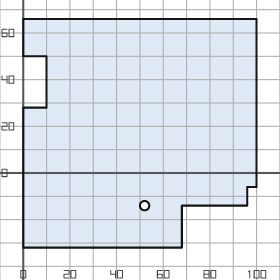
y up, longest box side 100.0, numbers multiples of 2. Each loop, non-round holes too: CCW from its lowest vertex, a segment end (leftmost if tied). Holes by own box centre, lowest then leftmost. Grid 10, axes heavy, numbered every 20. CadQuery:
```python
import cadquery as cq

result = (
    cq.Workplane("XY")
    .moveTo(0.0, -32.0)
    .lineTo(68.0, -32.0)
    .lineTo(68.0, -14.0)
    .lineTo(96.0, -14.0)
    .lineTo(96.0, -6.0)
    .lineTo(100.0, -6.0)
    .lineTo(100.0, 66.0)
    .lineTo(0.0, 66.0)
    .lineTo(0.0, 50.0)
    .lineTo(10.0, 50.0)
    .lineTo(10.0, 28.0)
    .lineTo(0.0, 28.0)
    .close()
    .moveTo(52.0, -14.0)
    .circle(2.0)
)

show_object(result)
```